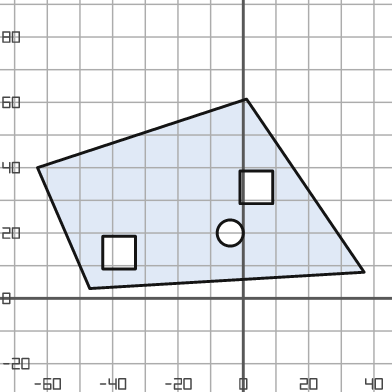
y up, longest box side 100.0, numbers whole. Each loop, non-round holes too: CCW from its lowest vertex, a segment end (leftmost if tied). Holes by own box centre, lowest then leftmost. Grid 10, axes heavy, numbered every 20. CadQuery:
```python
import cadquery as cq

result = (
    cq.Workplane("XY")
    .moveTo(-47.0, 3.0)
    .lineTo(37.0, 8.0)
    .lineTo(1.0, 61.0)
    .lineTo(-63.0, 40.0)
    .close()
    .moveTo(-43.0, 9.0)
    .lineTo(-33.0, 9.0)
    .lineTo(-33.0, 19.0)
    .lineTo(-43.0, 19.0)
    .close()
    .moveTo(-4.0, 20.0)
    .circle(4.0)
    .moveTo(-1.0, 29.0)
    .lineTo(9.0, 29.0)
    .lineTo(9.0, 39.0)
    .lineTo(-1.0, 39.0)
    .close()
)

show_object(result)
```